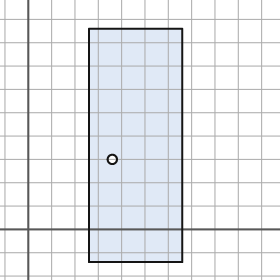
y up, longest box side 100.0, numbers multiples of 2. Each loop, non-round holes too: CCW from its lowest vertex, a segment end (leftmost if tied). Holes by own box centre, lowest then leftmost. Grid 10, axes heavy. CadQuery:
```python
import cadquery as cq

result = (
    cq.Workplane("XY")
    .moveTo(26.0, -14.0)
    .lineTo(66.0, -14.0)
    .lineTo(66.0, 86.0)
    .lineTo(26.0, 86.0)
    .close()
    .moveTo(36.0, 30.0)
    .circle(2.0)
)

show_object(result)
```